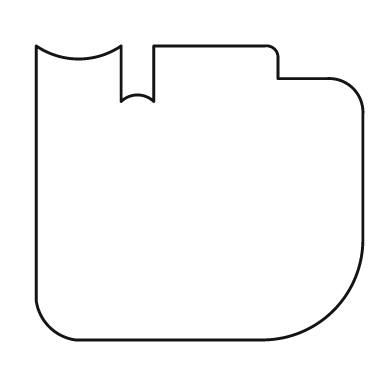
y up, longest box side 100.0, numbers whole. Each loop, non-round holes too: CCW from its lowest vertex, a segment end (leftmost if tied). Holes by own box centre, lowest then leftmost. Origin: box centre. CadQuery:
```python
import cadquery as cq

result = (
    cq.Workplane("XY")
    .moveTo(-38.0, -45.0)
    .lineTo(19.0, -45.0)
    .threePointArc((41.0, -36.0), (50.0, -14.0))
    .lineTo(50.0, 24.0)
    .threePointArc((47.0, 32.0), (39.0, 35.0))
    .lineTo(24.0, 35.0)
    .lineTo(24.0, 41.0)
    .threePointArc((23.0, 44.0), (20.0, 45.0))
    .lineTo(-14.0, 45.0)
    .lineTo(-14.0, 28.0)
    .threePointArc((-19.0, 30.0), (-24.0, 28.0))
    .lineTo(-24.0, 45.0)
    .threePointArc((-37.0, 41.0), (-50.0, 45.0))
    .lineTo(-50.0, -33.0)
    .threePointArc((-46.0, -41.0), (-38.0, -45.0))
    .close()
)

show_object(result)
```